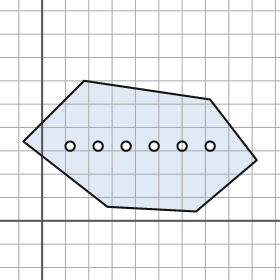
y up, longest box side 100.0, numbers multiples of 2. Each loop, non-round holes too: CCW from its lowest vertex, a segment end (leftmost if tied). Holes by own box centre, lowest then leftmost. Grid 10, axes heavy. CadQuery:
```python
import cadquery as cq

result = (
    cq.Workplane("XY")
    .moveTo(66.0, 4.0)
    .lineTo(92.0, 26.0)
    .lineTo(72.0, 52.0)
    .lineTo(18.0, 60.0)
    .lineTo(-8.0, 34.0)
    .lineTo(28.0, 6.0)
    .close()
    .moveTo(12.0, 32.0)
    .circle(2.0)
    .moveTo(24.0, 32.0)
    .circle(2.0)
    .moveTo(36.0, 32.0)
    .circle(2.0)
    .moveTo(48.0, 32.0)
    .circle(2.0)
    .moveTo(60.0, 32.0)
    .circle(2.0)
    .moveTo(72.0, 32.0)
    .circle(2.0)
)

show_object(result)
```